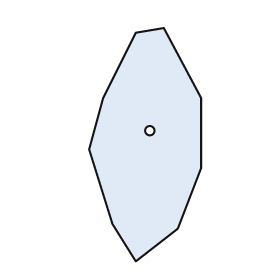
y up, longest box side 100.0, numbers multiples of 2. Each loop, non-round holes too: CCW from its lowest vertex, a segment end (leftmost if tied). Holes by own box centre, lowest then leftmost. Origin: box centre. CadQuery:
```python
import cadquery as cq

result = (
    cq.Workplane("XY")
    .moveTo(-4.0, -50.0)
    .lineTo(14.0, -36.0)
    .lineTo(24.0, -10.0)
    .lineTo(24.0, 20.0)
    .lineTo(8.0, 50.0)
    .lineTo(-4.0, 48.0)
    .lineTo(-18.0, 20.0)
    .lineTo(-24.0, -2.0)
    .lineTo(-14.0, -34.0)
    .close()
    .moveTo(2.0, 6.0)
    .circle(2.0)
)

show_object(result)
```